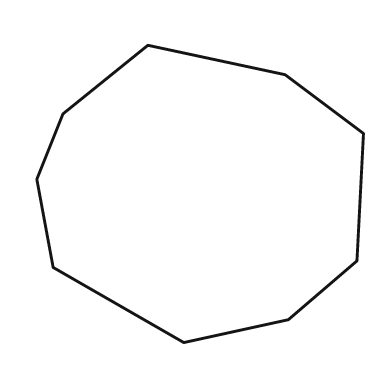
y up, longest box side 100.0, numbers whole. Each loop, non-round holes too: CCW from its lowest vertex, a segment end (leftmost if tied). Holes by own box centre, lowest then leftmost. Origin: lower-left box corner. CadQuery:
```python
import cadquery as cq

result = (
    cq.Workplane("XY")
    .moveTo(45.0, 0.0)
    .lineTo(77.0, 7.0)
    .lineTo(98.0, 25.0)
    .lineTo(100.0, 64.0)
    .lineTo(76.0, 82.0)
    .lineTo(34.0, 91.0)
    .lineTo(8.0, 70.0)
    .lineTo(0.0, 50.0)
    .lineTo(5.0, 23.0)
    .close()
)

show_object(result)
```